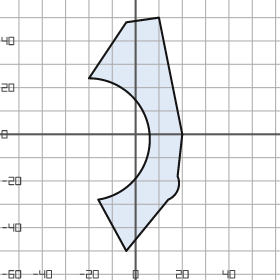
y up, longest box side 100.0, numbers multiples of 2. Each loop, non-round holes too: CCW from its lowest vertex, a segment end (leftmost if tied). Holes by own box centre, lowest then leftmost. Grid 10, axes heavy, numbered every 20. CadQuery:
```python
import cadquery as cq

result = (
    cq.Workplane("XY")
    .moveTo(-4.0, -50.0)
    .lineTo(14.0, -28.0)
    .threePointArc((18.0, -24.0), (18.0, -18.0))
    .lineTo(20.0, 0.0)
    .lineTo(10.0, 50.0)
    .lineTo(-4.0, 48.0)
    .lineTo(-20.0, 24.0)
    .threePointArc((6.0, 0.0), (-16.0, -28.0))
    .close()
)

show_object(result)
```